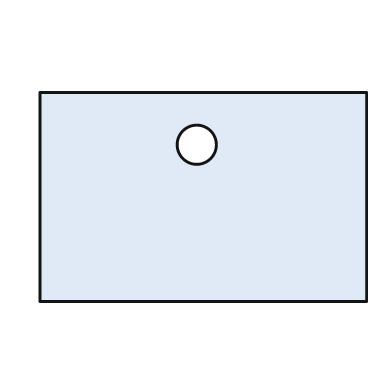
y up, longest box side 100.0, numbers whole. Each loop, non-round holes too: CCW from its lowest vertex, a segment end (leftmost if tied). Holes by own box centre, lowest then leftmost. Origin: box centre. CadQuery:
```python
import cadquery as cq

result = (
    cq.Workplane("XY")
    .moveTo(-50.0, -32.0)
    .lineTo(50.0, -32.0)
    .lineTo(50.0, 32.0)
    .lineTo(-50.0, 32.0)
    .close()
    .moveTo(-2.0, 16.0)
    .circle(6.0)
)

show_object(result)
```